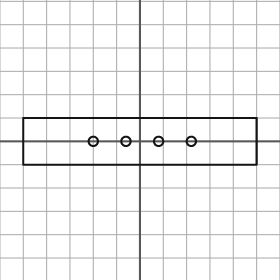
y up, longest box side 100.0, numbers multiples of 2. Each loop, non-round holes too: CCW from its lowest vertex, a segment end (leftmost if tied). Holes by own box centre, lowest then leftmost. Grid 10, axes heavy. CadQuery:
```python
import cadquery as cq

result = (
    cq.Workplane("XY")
    .moveTo(-50.0, -10.0)
    .lineTo(50.0, -10.0)
    .lineTo(50.0, 10.0)
    .lineTo(-50.0, 10.0)
    .close()
    .moveTo(-20.0, 0.0)
    .circle(2.0)
    .moveTo(-6.0, 0.0)
    .circle(2.0)
    .moveTo(8.0, 0.0)
    .circle(2.0)
    .moveTo(22.0, 0.0)
    .circle(2.0)
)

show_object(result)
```